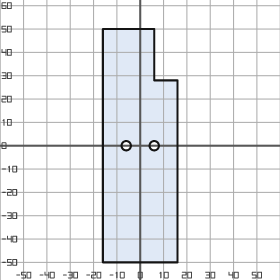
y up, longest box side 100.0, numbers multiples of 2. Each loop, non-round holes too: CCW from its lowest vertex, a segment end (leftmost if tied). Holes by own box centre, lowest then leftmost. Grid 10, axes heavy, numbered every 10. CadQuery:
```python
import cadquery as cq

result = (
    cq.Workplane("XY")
    .moveTo(-16.0, -50.0)
    .lineTo(16.0, -50.0)
    .lineTo(16.0, 28.0)
    .lineTo(6.0, 28.0)
    .lineTo(6.0, 50.0)
    .lineTo(-16.0, 50.0)
    .close()
    .moveTo(-6.0, 0.0)
    .circle(2.0)
    .moveTo(6.0, 0.0)
    .circle(2.0)
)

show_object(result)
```